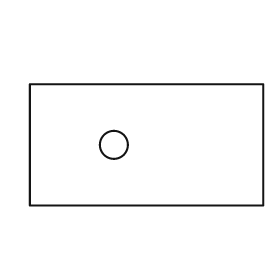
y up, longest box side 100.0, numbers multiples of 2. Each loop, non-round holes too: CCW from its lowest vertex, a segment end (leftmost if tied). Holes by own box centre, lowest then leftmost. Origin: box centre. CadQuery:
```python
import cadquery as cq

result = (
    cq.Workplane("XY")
    .moveTo(-50.0, -26.0)
    .lineTo(50.0, -26.0)
    .lineTo(50.0, 26.0)
    .lineTo(-50.0, 26.0)
    .close()
    .moveTo(-14.0, 0.0)
    .circle(6.0)
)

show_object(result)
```